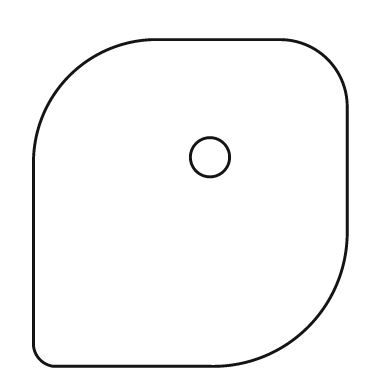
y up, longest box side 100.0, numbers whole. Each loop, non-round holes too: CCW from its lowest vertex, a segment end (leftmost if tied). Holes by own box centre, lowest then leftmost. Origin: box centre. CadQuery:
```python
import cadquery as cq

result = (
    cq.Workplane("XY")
    .moveTo(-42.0, -50.0)
    .lineTo(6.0, -50.0)
    .threePointArc((36.0, -38.0), (48.0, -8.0))
    .lineTo(48.0, 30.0)
    .threePointArc((42.0, 44.0), (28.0, 50.0))
    .lineTo(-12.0, 50.0)
    .threePointArc((-37.0, 39.0), (-48.0, 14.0))
    .lineTo(-48.0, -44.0)
    .threePointArc((-46.0, -48.0), (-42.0, -50.0))
    .close()
    .moveTo(6.0, 14.0)
    .circle(6.0)
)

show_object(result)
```